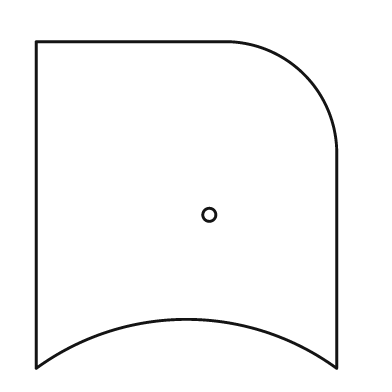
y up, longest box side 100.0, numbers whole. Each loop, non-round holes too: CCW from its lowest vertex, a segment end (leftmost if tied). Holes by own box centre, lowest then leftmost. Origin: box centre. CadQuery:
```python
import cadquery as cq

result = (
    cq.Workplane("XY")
    .moveTo(-46.0, -50.0)
    .threePointArc((0.0, -35.0), (46.0, -50.0))
    .lineTo(46.0, 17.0)
    .threePointArc((36.0, 40.0), (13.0, 50.0))
    .lineTo(-46.0, 50.0)
    .close()
    .moveTo(7.0, -3.0)
    .circle(2.0)
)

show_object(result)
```